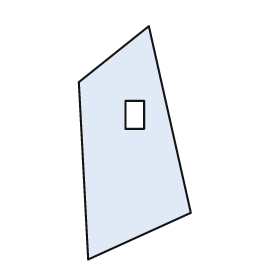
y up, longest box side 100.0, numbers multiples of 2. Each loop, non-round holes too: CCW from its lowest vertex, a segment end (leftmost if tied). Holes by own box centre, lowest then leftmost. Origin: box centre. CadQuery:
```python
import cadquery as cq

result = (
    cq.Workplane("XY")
    .moveTo(-20.0, -50.0)
    .lineTo(24.0, -30.0)
    .lineTo(6.0, 50.0)
    .lineTo(-24.0, 26.0)
    .close()
    .moveTo(-4.0, 6.0)
    .lineTo(4.0, 6.0)
    .lineTo(4.0, 18.0)
    .lineTo(-4.0, 18.0)
    .close()
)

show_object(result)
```